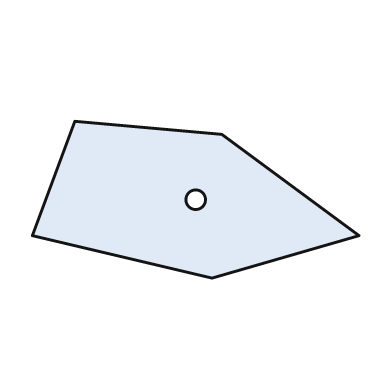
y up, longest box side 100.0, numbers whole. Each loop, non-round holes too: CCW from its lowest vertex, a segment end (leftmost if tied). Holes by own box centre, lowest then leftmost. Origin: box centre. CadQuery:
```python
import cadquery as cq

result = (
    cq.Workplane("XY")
    .moveTo(5.0, -24.0)
    .lineTo(50.0, -11.0)
    .lineTo(8.0, 20.0)
    .lineTo(-37.0, 24.0)
    .lineTo(-50.0, -11.0)
    .close()
    .moveTo(0.0, 0.0)
    .circle(3.0)
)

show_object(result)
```